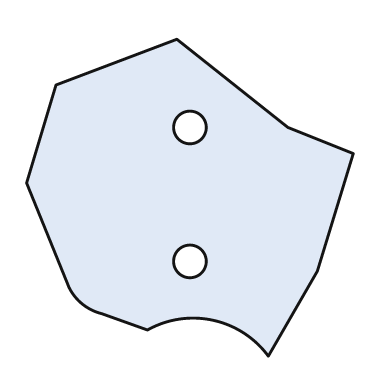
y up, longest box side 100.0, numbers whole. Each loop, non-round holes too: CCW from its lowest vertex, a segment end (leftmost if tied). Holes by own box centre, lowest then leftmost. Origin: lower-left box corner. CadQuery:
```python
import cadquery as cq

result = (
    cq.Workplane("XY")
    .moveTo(74.0, 0.0)
    .lineTo(89.0, 26.0)
    .lineTo(100.0, 62.0)
    .lineTo(80.0, 70.0)
    .lineTo(46.0, 97.0)
    .lineTo(9.0, 83.0)
    .lineTo(0.0, 53.0)
    .lineTo(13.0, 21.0)
    .threePointArc((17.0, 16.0), (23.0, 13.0))
    .lineTo(37.0, 8.0)
    .threePointArc((57.0, 11.0), (74.0, 0.0))
    .close()
    .moveTo(50.0, 29.0)
    .circle(5.0)
    .moveTo(50.0, 70.0)
    .circle(5.0)
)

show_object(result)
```